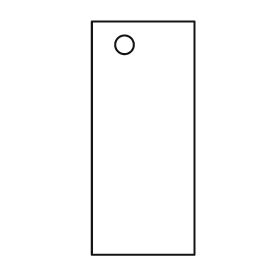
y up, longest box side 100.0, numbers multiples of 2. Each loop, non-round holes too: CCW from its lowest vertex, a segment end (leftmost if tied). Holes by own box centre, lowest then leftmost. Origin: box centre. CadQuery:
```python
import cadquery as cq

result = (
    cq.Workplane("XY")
    .moveTo(-22.0, -50.0)
    .lineTo(22.0, -50.0)
    .lineTo(22.0, 50.0)
    .lineTo(-22.0, 50.0)
    .close()
    .moveTo(-8.0, 40.0)
    .circle(4.0)
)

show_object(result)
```